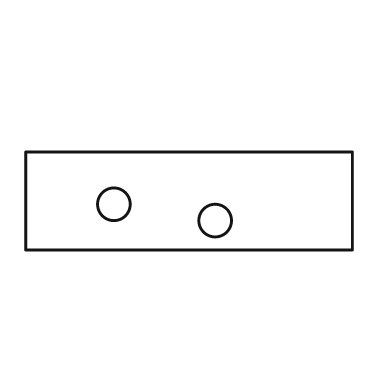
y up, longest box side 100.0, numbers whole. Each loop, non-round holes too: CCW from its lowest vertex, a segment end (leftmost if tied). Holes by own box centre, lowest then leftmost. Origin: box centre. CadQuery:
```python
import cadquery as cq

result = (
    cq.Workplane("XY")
    .moveTo(-50.0, -15.0)
    .lineTo(50.0, -15.0)
    .lineTo(50.0, 15.0)
    .lineTo(-50.0, 15.0)
    .close()
    .moveTo(8.0, -6.0)
    .circle(5.0)
    .moveTo(-23.0, -1.0)
    .circle(5.0)
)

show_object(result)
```